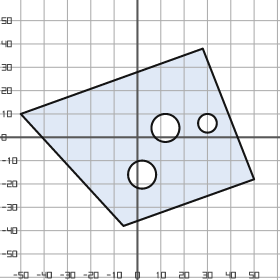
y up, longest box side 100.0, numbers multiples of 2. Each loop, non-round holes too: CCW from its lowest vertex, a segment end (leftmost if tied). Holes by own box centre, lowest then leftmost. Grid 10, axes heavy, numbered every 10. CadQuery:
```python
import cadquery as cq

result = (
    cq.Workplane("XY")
    .moveTo(-6.0, -38.0)
    .lineTo(50.0, -18.0)
    .lineTo(28.0, 38.0)
    .lineTo(-50.0, 10.0)
    .close()
    .moveTo(2.0, -16.0)
    .circle(6.0)
    .moveTo(12.0, 4.0)
    .circle(6.0)
    .moveTo(30.0, 6.0)
    .circle(4.0)
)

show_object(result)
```